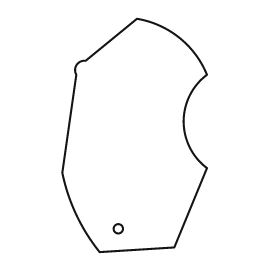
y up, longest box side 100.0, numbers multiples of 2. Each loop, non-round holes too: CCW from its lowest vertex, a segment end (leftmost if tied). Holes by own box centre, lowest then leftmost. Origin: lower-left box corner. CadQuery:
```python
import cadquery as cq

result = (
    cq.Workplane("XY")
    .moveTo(16.0, 0.0)
    .lineTo(48.0, 2.0)
    .lineTo(62.0, 36.0)
    .threePointArc((52.0, 56.0), (62.0, 76.0))
    .threePointArc((50.0, 92.0), (32.0, 100.0))
    .lineTo(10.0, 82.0)
    .threePointArc((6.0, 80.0), (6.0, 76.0))
    .lineTo(0.0, 34.0)
    .threePointArc((6.0, 16.0), (16.0, 0.0))
    .close()
    .moveTo(24.0, 10.0)
    .circle(2.0)
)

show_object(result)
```